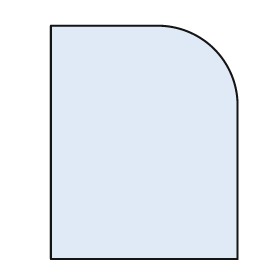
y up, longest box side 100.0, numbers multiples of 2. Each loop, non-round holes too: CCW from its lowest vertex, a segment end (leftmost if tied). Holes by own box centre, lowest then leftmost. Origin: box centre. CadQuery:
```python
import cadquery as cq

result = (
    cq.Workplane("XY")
    .moveTo(-40.0, -50.0)
    .lineTo(40.0, -50.0)
    .lineTo(40.0, 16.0)
    .threePointArc((30.0, 40.0), (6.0, 50.0))
    .lineTo(-40.0, 50.0)
    .close()
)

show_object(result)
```